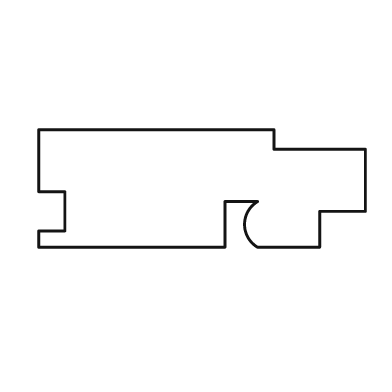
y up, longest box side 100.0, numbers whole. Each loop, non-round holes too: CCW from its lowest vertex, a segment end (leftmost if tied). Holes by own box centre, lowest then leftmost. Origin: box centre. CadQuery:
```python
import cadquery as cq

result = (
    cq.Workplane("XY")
    .moveTo(-50.0, -18.0)
    .lineTo(7.0, -18.0)
    .lineTo(7.0, -4.0)
    .lineTo(17.0, -4.0)
    .threePointArc((13.0, -11.0), (17.0, -18.0))
    .lineTo(36.0, -18.0)
    .lineTo(36.0, -7.0)
    .lineTo(50.0, -7.0)
    .lineTo(50.0, 12.0)
    .lineTo(22.0, 12.0)
    .lineTo(22.0, 18.0)
    .lineTo(-50.0, 18.0)
    .lineTo(-50.0, -1.0)
    .lineTo(-42.0, -1.0)
    .lineTo(-42.0, -13.0)
    .lineTo(-50.0, -13.0)
    .close()
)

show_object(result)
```